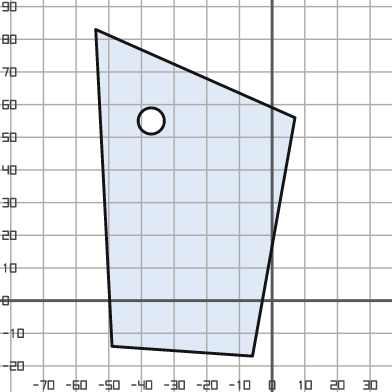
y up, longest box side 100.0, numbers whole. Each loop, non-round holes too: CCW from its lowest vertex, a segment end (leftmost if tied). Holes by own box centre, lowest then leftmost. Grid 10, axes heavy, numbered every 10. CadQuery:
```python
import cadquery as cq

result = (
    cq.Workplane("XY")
    .moveTo(-6.0, -17.0)
    .lineTo(7.0, 56.0)
    .lineTo(-54.0, 83.0)
    .lineTo(-49.0, -14.0)
    .close()
    .moveTo(-37.0, 55.0)
    .circle(4.0)
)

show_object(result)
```